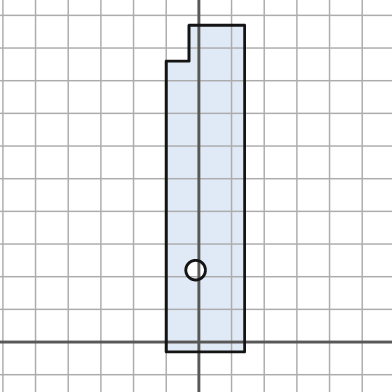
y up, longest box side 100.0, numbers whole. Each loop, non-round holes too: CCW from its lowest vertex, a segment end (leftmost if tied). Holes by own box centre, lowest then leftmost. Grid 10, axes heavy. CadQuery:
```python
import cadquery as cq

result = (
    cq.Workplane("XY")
    .moveTo(-10.0, -3.0)
    .lineTo(14.0, -3.0)
    .lineTo(14.0, 97.0)
    .lineTo(-3.0, 97.0)
    .lineTo(-3.0, 86.0)
    .lineTo(-10.0, 86.0)
    .close()
    .moveTo(-1.0, 22.0)
    .circle(3.0)
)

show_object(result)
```